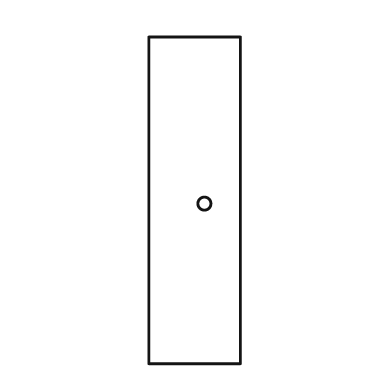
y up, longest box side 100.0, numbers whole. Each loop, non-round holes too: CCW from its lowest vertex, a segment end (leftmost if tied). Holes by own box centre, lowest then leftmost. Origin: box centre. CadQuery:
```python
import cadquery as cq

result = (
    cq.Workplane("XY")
    .moveTo(-14.0, -50.0)
    .lineTo(14.0, -50.0)
    .lineTo(14.0, 50.0)
    .lineTo(-14.0, 50.0)
    .close()
    .moveTo(3.0, -1.0)
    .circle(2.0)
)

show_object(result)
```